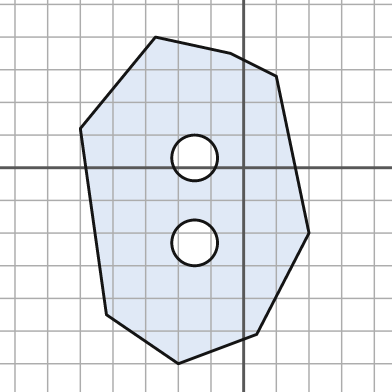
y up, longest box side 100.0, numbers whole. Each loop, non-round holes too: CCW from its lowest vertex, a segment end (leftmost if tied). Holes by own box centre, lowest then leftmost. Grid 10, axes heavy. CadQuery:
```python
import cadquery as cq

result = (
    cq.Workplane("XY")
    .moveTo(-20.0, -60.0)
    .lineTo(4.0, -51.0)
    .lineTo(20.0, -20.0)
    .lineTo(10.0, 28.0)
    .lineTo(-4.0, 35.0)
    .lineTo(-27.0, 40.0)
    .lineTo(-50.0, 12.0)
    .lineTo(-42.0, -45.0)
    .close()
    .moveTo(-15.0, -23.0)
    .circle(7.0)
    .moveTo(-15.0, 3.0)
    .circle(7.0)
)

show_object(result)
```